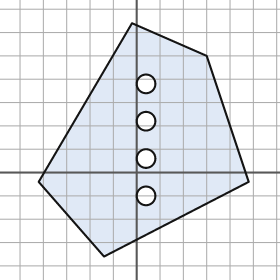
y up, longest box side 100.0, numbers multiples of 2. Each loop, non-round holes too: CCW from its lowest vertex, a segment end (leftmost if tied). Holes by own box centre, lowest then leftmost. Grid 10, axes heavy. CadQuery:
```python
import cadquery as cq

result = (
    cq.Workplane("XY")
    .moveTo(-14.0, -36.0)
    .lineTo(48.0, -4.0)
    .lineTo(30.0, 50.0)
    .lineTo(-2.0, 64.0)
    .lineTo(-42.0, -4.0)
    .close()
    .moveTo(4.0, -10.0)
    .circle(4.0)
    .moveTo(4.0, 6.0)
    .circle(4.0)
    .moveTo(4.0, 22.0)
    .circle(4.0)
    .moveTo(4.0, 38.0)
    .circle(4.0)
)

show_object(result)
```